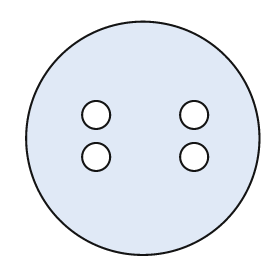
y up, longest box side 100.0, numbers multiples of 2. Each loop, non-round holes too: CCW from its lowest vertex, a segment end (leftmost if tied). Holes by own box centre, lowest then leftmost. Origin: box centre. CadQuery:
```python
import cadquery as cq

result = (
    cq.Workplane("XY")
    .moveTo(0.0, 0.0)
    .circle(50.0)
    .moveTo(-20.0, -8.0)
    .circle(6.0)
    .moveTo(22.0, -8.0)
    .circle(6.0)
    .moveTo(-20.0, 10.0)
    .circle(6.0)
    .moveTo(22.0, 10.0)
    .circle(6.0)
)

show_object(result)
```